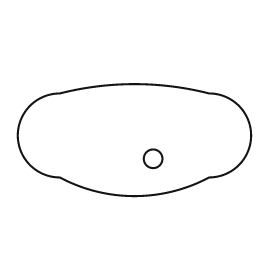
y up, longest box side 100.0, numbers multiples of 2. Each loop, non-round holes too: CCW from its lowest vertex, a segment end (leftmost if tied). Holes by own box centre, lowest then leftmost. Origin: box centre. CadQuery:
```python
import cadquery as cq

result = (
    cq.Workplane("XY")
    .moveTo(-32.0, -16.0)
    .threePointArc((0.0, -24.0), (32.0, -16.0))
    .threePointArc((50.0, 2.0), (32.0, 20.0))
    .threePointArc((0.0, 24.0), (-32.0, 20.0))
    .threePointArc((-50.0, 2.0), (-32.0, -16.0))
    .close()
    .moveTo(8.0, -8.0)
    .circle(4.0)
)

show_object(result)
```